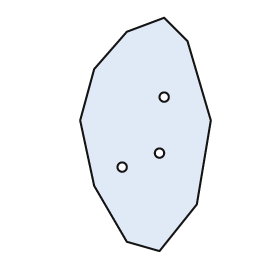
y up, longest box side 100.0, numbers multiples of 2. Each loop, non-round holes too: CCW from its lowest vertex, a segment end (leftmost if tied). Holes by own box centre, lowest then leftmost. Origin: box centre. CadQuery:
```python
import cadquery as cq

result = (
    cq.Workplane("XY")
    .moveTo(6.0, -50.0)
    .lineTo(22.0, -30.0)
    .lineTo(28.0, 6.0)
    .lineTo(18.0, 40.0)
    .lineTo(8.0, 50.0)
    .lineTo(-8.0, 44.0)
    .lineTo(-22.0, 28.0)
    .lineTo(-28.0, 6.0)
    .lineTo(-22.0, -22.0)
    .lineTo(-8.0, -46.0)
    .close()
    .moveTo(-10.0, -14.0)
    .circle(2.0)
    .moveTo(6.0, -8.0)
    .circle(2.0)
    .moveTo(8.0, 16.0)
    .circle(2.0)
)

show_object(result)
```